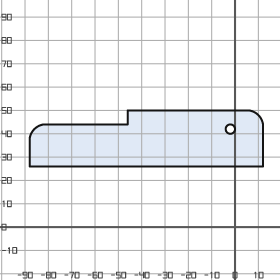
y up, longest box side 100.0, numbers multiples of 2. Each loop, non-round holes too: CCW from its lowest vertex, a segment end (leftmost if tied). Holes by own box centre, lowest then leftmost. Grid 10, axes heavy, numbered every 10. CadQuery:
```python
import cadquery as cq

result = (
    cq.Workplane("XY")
    .moveTo(-88.0, 26.0)
    .lineTo(12.0, 26.0)
    .lineTo(12.0, 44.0)
    .threePointArc((10.0, 48.0), (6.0, 50.0))
    .lineTo(-46.0, 50.0)
    .lineTo(-46.0, 44.0)
    .lineTo(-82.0, 44.0)
    .threePointArc((-86.0, 42.0), (-88.0, 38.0))
    .close()
    .moveTo(-2.0, 42.0)
    .circle(2.0)
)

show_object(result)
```